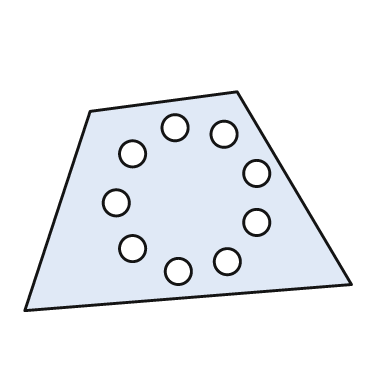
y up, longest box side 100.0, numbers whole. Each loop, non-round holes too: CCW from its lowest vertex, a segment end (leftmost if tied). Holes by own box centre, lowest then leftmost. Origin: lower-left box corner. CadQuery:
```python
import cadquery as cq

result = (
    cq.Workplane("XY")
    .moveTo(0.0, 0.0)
    .lineTo(100.0, 8.0)
    .lineTo(65.0, 67.0)
    .lineTo(20.0, 61.0)
    .close()
    .moveTo(47.0, 12.0)
    .circle(4.0)
    .moveTo(62.0, 15.0)
    .circle(4.0)
    .moveTo(33.0, 19.0)
    .circle(4.0)
    .moveTo(71.0, 27.0)
    .circle(4.0)
    .moveTo(28.0, 33.0)
    .circle(4.0)
    .moveTo(71.0, 42.0)
    .circle(4.0)
    .moveTo(33.0, 48.0)
    .circle(4.0)
    .moveTo(61.0, 54.0)
    .circle(4.0)
    .moveTo(46.0, 56.0)
    .circle(4.0)
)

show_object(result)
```